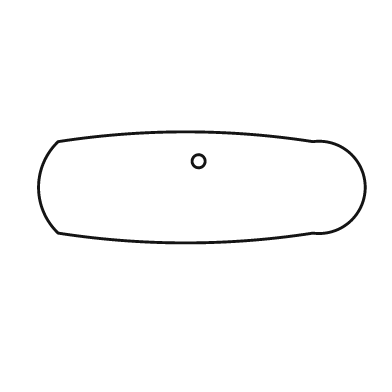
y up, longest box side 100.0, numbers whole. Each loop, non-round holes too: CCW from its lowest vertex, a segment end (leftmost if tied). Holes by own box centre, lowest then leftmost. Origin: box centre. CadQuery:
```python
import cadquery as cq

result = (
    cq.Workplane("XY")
    .moveTo(-44.0, -14.0)
    .threePointArc((-5.0, -17.0), (34.0, -14.0))
    .threePointArc((50.0, 0.0), (34.0, 14.0))
    .threePointArc((-5.0, 17.0), (-44.0, 14.0))
    .threePointArc((-50.0, 0.0), (-44.0, -14.0))
    .close()
    .moveTo(-1.0, 8.0)
    .circle(2.0)
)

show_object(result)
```